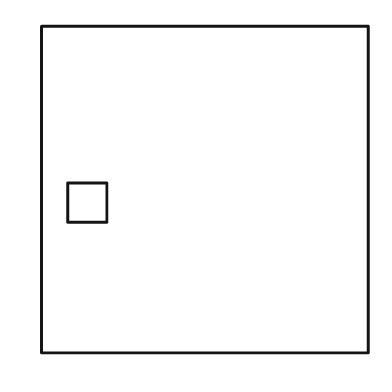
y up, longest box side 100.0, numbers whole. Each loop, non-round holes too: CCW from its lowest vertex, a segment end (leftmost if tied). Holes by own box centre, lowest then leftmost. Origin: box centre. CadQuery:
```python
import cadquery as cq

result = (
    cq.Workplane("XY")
    .moveTo(-50.0, -50.0)
    .lineTo(50.0, -50.0)
    .lineTo(50.0, 50.0)
    .lineTo(-50.0, 50.0)
    .close()
    .moveTo(-42.0, -10.0)
    .lineTo(-30.0, -10.0)
    .lineTo(-30.0, 2.0)
    .lineTo(-42.0, 2.0)
    .close()
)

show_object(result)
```